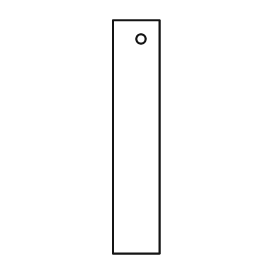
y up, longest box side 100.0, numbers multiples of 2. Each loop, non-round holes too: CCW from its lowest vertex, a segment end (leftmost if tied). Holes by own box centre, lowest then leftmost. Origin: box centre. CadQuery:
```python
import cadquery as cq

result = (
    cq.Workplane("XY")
    .moveTo(-10.0, -50.0)
    .lineTo(10.0, -50.0)
    .lineTo(10.0, 50.0)
    .lineTo(-10.0, 50.0)
    .close()
    .moveTo(2.0, 42.0)
    .circle(2.0)
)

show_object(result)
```